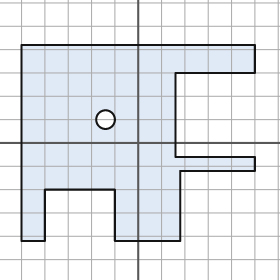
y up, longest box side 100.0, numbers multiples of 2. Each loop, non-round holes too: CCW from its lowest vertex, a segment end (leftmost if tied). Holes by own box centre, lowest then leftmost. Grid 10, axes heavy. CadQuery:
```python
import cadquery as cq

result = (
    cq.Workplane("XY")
    .moveTo(-50.0, -42.0)
    .lineTo(-40.0, -42.0)
    .lineTo(-40.0, -20.0)
    .lineTo(-10.0, -20.0)
    .lineTo(-10.0, -42.0)
    .lineTo(18.0, -42.0)
    .lineTo(18.0, -12.0)
    .lineTo(50.0, -12.0)
    .lineTo(50.0, -6.0)
    .lineTo(16.0, -6.0)
    .lineTo(16.0, 30.0)
    .lineTo(50.0, 30.0)
    .lineTo(50.0, 42.0)
    .lineTo(-50.0, 42.0)
    .close()
    .moveTo(-14.0, 10.0)
    .circle(4.0)
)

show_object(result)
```